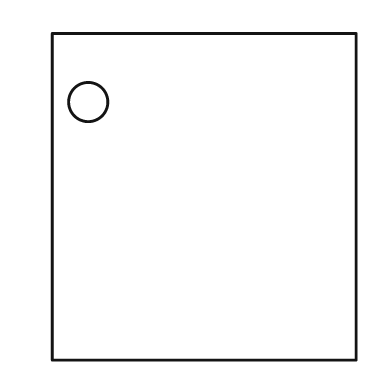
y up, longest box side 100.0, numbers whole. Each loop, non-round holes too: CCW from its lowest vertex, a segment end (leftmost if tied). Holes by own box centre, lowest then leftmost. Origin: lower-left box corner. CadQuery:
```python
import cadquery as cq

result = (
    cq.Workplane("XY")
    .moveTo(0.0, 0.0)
    .lineTo(93.0, 0.0)
    .lineTo(93.0, 100.0)
    .lineTo(0.0, 100.0)
    .close()
    .moveTo(11.0, 79.0)
    .circle(6.0)
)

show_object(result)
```